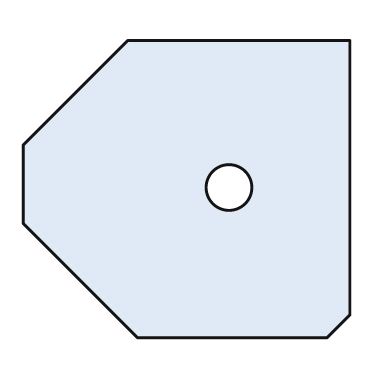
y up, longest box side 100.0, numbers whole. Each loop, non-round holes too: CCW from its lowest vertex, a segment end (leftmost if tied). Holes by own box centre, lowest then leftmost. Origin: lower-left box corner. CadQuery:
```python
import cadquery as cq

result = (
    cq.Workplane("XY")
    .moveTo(35.0, 0.0)
    .lineTo(93.0, 0.0)
    .lineTo(100.0, 7.0)
    .lineTo(100.0, 91.0)
    .lineTo(32.0, 91.0)
    .lineTo(0.0, 59.0)
    .lineTo(0.0, 35.0)
    .close()
    .moveTo(63.0, 46.0)
    .circle(7.0)
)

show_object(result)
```